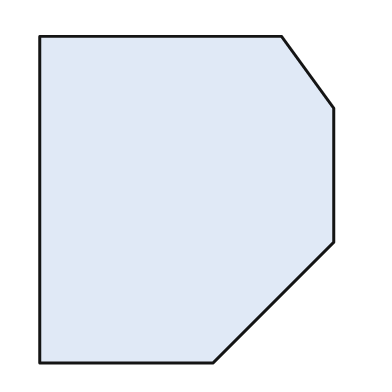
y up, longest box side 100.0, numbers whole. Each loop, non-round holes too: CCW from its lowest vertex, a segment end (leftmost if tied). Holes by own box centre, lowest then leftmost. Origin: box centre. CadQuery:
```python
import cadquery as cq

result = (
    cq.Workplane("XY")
    .moveTo(-45.0, -50.0)
    .lineTo(8.0, -50.0)
    .lineTo(45.0, -13.0)
    .lineTo(45.0, 28.0)
    .lineTo(29.0, 50.0)
    .lineTo(-45.0, 50.0)
    .close()
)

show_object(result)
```